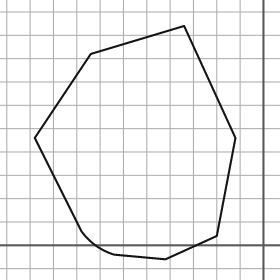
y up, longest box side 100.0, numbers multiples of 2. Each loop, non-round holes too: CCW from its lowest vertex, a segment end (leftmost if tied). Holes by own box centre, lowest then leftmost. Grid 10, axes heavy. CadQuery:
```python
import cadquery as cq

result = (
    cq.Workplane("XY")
    .moveTo(-42.0, -6.0)
    .lineTo(-20.0, 4.0)
    .lineTo(-12.0, 46.0)
    .lineTo(-34.0, 94.0)
    .lineTo(-74.0, 82.0)
    .lineTo(-98.0, 46.0)
    .lineTo(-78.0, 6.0)
    .threePointArc((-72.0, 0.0), (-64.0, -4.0))
    .close()
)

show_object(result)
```